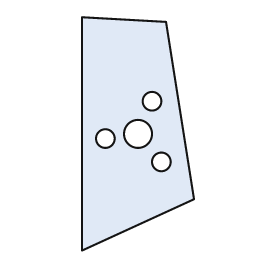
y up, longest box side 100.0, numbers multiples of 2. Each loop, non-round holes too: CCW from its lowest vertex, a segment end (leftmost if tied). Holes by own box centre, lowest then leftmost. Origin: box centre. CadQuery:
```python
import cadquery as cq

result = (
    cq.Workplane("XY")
    .moveTo(-24.0, -50.0)
    .lineTo(24.0, -28.0)
    .lineTo(12.0, 48.0)
    .lineTo(-24.0, 50.0)
    .close()
    .moveTo(10.0, -12.0)
    .circle(4.0)
    .moveTo(-14.0, -2.0)
    .circle(4.0)
    .moveTo(0.0, 0.0)
    .circle(6.0)
    .moveTo(6.0, 14.0)
    .circle(4.0)
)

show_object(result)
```